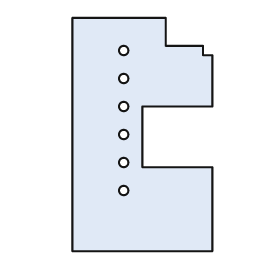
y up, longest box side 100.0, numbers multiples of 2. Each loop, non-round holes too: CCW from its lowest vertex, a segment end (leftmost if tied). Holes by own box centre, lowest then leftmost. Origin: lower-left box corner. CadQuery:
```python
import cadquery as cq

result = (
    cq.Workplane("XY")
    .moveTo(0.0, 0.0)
    .lineTo(60.0, 0.0)
    .lineTo(60.0, 36.0)
    .lineTo(30.0, 36.0)
    .lineTo(30.0, 62.0)
    .lineTo(60.0, 62.0)
    .lineTo(60.0, 84.0)
    .lineTo(56.0, 84.0)
    .lineTo(56.0, 88.0)
    .lineTo(40.0, 88.0)
    .lineTo(40.0, 100.0)
    .lineTo(0.0, 100.0)
    .close()
    .moveTo(22.0, 26.0)
    .circle(2.0)
    .moveTo(22.0, 38.0)
    .circle(2.0)
    .moveTo(22.0, 50.0)
    .circle(2.0)
    .moveTo(22.0, 62.0)
    .circle(2.0)
    .moveTo(22.0, 74.0)
    .circle(2.0)
    .moveTo(22.0, 86.0)
    .circle(2.0)
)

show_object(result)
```